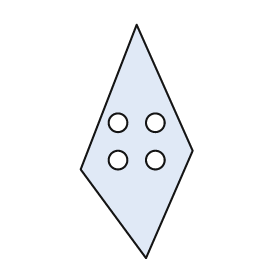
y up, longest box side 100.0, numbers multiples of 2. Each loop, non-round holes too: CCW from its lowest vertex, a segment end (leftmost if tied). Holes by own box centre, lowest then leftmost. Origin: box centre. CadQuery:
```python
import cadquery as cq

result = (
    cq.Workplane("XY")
    .moveTo(4.0, -50.0)
    .lineTo(24.0, -4.0)
    .lineTo(0.0, 50.0)
    .lineTo(-24.0, -12.0)
    .close()
    .moveTo(-8.0, -8.0)
    .circle(4.0)
    .moveTo(8.0, -8.0)
    .circle(4.0)
    .moveTo(-8.0, 8.0)
    .circle(4.0)
    .moveTo(8.0, 8.0)
    .circle(4.0)
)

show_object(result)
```